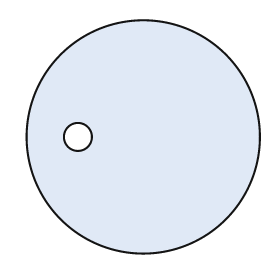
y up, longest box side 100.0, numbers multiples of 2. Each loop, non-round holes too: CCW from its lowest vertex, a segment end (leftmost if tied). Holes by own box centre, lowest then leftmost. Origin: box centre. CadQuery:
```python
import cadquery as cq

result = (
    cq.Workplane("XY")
    .moveTo(0.0, 0.0)
    .circle(50.0)
    .moveTo(-28.0, 0.0)
    .circle(6.0)
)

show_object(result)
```